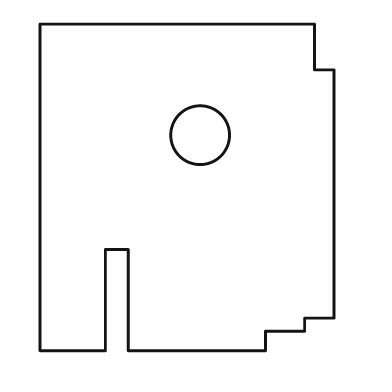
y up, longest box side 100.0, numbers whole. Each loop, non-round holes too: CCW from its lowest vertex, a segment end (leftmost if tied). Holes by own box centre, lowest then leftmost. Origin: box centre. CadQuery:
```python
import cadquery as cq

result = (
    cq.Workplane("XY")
    .moveTo(-45.0, -50.0)
    .lineTo(-25.0, -50.0)
    .lineTo(-25.0, -19.0)
    .lineTo(-18.0, -19.0)
    .lineTo(-18.0, -50.0)
    .lineTo(24.0, -50.0)
    .lineTo(24.0, -44.0)
    .lineTo(36.0, -44.0)
    .lineTo(36.0, -40.0)
    .lineTo(45.0, -40.0)
    .lineTo(45.0, 36.0)
    .lineTo(39.0, 36.0)
    .lineTo(39.0, 50.0)
    .lineTo(-45.0, 50.0)
    .close()
    .moveTo(4.0, 16.0)
    .circle(9.0)
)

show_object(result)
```